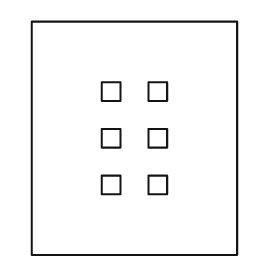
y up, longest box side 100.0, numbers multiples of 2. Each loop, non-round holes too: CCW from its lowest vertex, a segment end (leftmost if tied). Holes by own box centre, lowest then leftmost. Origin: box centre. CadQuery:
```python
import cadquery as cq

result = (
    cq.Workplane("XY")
    .moveTo(-44.0, -50.0)
    .lineTo(44.0, -50.0)
    .lineTo(44.0, 50.0)
    .lineTo(-44.0, 50.0)
    .close()
    .moveTo(-14.0, -24.0)
    .lineTo(-6.0, -24.0)
    .lineTo(-6.0, -16.0)
    .lineTo(-14.0, -16.0)
    .close()
    .moveTo(6.0, -24.0)
    .lineTo(14.0, -24.0)
    .lineTo(14.0, -16.0)
    .lineTo(6.0, -16.0)
    .close()
    .moveTo(-14.0, -4.0)
    .lineTo(-6.0, -4.0)
    .lineTo(-6.0, 4.0)
    .lineTo(-14.0, 4.0)
    .close()
    .moveTo(6.0, -4.0)
    .lineTo(14.0, -4.0)
    .lineTo(14.0, 4.0)
    .lineTo(6.0, 4.0)
    .close()
    .moveTo(-14.0, 16.0)
    .lineTo(-6.0, 16.0)
    .lineTo(-6.0, 24.0)
    .lineTo(-14.0, 24.0)
    .close()
    .moveTo(6.0, 16.0)
    .lineTo(14.0, 16.0)
    .lineTo(14.0, 24.0)
    .lineTo(6.0, 24.0)
    .close()
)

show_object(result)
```